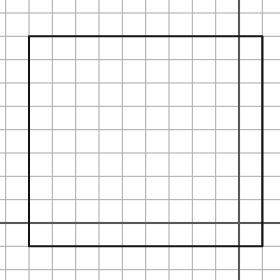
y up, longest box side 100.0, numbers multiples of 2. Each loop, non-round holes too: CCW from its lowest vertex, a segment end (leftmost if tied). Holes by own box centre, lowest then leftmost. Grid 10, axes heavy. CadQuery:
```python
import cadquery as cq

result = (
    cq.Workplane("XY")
    .moveTo(-90.0, -10.0)
    .lineTo(10.0, -10.0)
    .lineTo(10.0, 80.0)
    .lineTo(-90.0, 80.0)
    .close()
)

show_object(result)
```